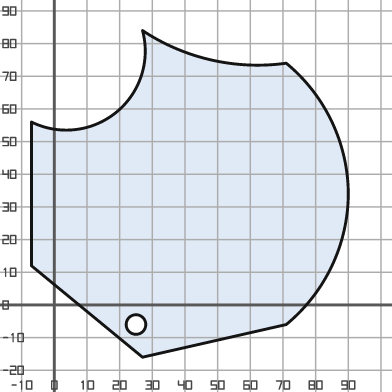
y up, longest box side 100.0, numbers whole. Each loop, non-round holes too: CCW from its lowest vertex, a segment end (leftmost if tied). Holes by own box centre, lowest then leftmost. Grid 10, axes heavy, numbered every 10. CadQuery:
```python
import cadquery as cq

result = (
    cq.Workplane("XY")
    .moveTo(27.0, -16.0)
    .lineTo(71.0, -6.0)
    .threePointArc((85.0, 12.0), (90.0, 34.0))
    .threePointArc((85.0, 56.0), (71.0, 74.0))
    .threePointArc((48.0, 75.0), (27.0, 84.0))
    .threePointArc((19.0, 59.0), (-7.0, 56.0))
    .lineTo(-7.0, 12.0)
    .close()
    .moveTo(25.0, -6.0)
    .circle(3.0)
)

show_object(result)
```